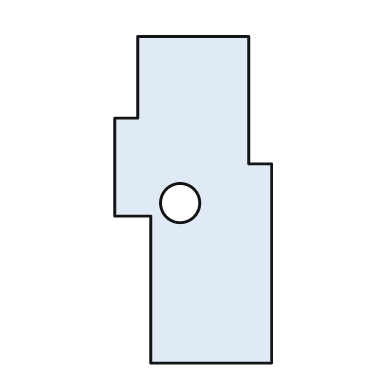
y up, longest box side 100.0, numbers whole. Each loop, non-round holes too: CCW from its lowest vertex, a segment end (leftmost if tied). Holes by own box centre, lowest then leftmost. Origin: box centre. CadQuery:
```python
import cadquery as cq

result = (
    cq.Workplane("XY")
    .moveTo(-13.0, -50.0)
    .lineTo(24.0, -50.0)
    .lineTo(24.0, 11.0)
    .lineTo(17.0, 11.0)
    .lineTo(17.0, 50.0)
    .lineTo(-17.0, 50.0)
    .lineTo(-17.0, 25.0)
    .lineTo(-24.0, 25.0)
    .lineTo(-24.0, -5.0)
    .lineTo(-13.0, -5.0)
    .close()
    .moveTo(-4.0, -1.0)
    .circle(6.0)
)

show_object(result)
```